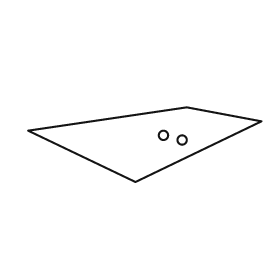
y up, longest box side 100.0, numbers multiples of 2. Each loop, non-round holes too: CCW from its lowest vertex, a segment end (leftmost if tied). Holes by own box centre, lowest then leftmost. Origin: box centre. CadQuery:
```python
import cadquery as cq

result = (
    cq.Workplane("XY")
    .moveTo(-4.0, -16.0)
    .lineTo(50.0, 10.0)
    .lineTo(18.0, 16.0)
    .lineTo(-50.0, 6.0)
    .close()
    .moveTo(16.0, 2.0)
    .circle(2.0)
    .moveTo(8.0, 4.0)
    .circle(2.0)
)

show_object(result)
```